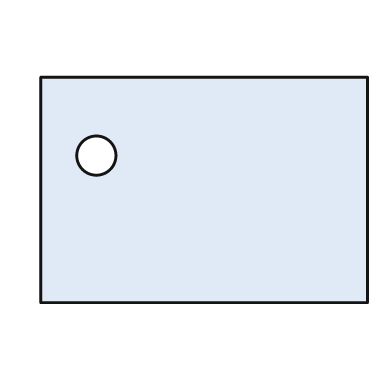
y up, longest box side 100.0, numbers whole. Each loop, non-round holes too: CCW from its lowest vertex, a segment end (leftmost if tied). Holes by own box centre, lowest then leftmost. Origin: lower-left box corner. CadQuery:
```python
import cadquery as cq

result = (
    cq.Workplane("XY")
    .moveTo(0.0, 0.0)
    .lineTo(100.0, 0.0)
    .lineTo(100.0, 69.0)
    .lineTo(0.0, 69.0)
    .close()
    .moveTo(17.0, 45.0)
    .circle(6.0)
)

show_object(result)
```